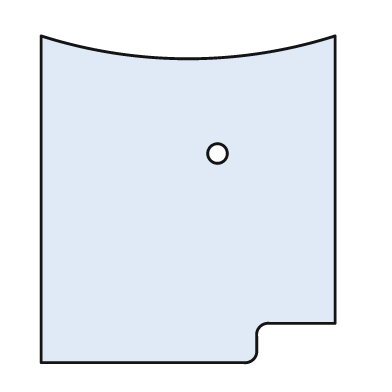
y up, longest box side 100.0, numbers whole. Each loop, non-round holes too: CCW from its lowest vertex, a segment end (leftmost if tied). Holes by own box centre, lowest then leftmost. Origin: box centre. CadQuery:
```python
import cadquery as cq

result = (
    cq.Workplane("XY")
    .moveTo(-45.0, -50.0)
    .lineTo(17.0, -50.0)
    .threePointArc((20.0, -49.0), (21.0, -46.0))
    .lineTo(21.0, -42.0)
    .threePointArc((22.0, -39.0), (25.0, -38.0))
    .lineTo(45.0, -38.0)
    .lineTo(45.0, 50.0)
    .threePointArc((0.0, 43.0), (-45.0, 50.0))
    .close()
    .moveTo(9.0, 14.0)
    .circle(3.0)
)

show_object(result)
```